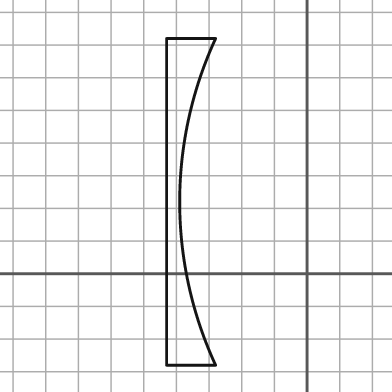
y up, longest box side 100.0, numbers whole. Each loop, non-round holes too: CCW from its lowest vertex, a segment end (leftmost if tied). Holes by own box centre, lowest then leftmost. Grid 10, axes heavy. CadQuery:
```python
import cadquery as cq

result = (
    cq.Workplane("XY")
    .moveTo(-43.0, -28.0)
    .lineTo(-28.0, -28.0)
    .threePointArc((-39.0, 22.0), (-28.0, 72.0))
    .lineTo(-43.0, 72.0)
    .close()
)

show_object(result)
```